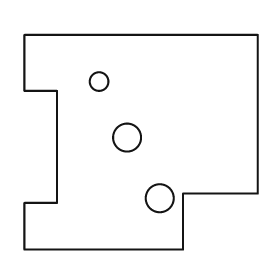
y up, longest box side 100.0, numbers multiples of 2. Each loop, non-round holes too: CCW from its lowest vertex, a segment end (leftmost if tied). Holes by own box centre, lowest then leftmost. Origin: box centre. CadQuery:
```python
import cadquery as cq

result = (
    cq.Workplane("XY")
    .moveTo(-50.0, -46.0)
    .lineTo(18.0, -46.0)
    .lineTo(18.0, -22.0)
    .lineTo(50.0, -22.0)
    .lineTo(50.0, 46.0)
    .lineTo(-50.0, 46.0)
    .lineTo(-50.0, 22.0)
    .lineTo(-36.0, 22.0)
    .lineTo(-36.0, -26.0)
    .lineTo(-50.0, -26.0)
    .close()
    .moveTo(8.0, -24.0)
    .circle(6.0)
    .moveTo(-6.0, 2.0)
    .circle(6.0)
    .moveTo(-18.0, 26.0)
    .circle(4.0)
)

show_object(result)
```